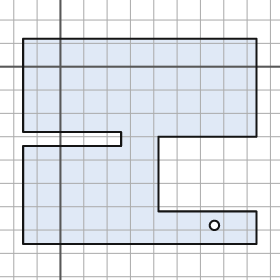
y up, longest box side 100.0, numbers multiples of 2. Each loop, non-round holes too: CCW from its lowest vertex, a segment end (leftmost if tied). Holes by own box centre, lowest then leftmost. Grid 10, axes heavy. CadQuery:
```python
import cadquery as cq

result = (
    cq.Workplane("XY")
    .moveTo(-16.0, -76.0)
    .lineTo(84.0, -76.0)
    .lineTo(84.0, -62.0)
    .lineTo(42.0, -62.0)
    .lineTo(42.0, -30.0)
    .lineTo(84.0, -30.0)
    .lineTo(84.0, 12.0)
    .lineTo(-16.0, 12.0)
    .lineTo(-16.0, -28.0)
    .lineTo(26.0, -28.0)
    .lineTo(26.0, -34.0)
    .lineTo(-16.0, -34.0)
    .close()
    .moveTo(66.0, -68.0)
    .circle(2.0)
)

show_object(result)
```